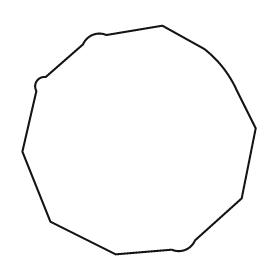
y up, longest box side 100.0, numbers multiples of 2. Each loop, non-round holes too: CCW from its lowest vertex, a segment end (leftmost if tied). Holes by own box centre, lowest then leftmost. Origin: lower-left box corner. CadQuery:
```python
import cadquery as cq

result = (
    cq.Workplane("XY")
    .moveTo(40.0, 0.0)
    .lineTo(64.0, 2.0)
    .threePointArc((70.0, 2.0), (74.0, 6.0))
    .lineTo(94.0, 24.0)
    .lineTo(100.0, 54.0)
    .lineTo(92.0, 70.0)
    .threePointArc((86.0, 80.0), (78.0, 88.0))
    .lineTo(60.0, 98.0)
    .lineTo(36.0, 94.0)
    .threePointArc((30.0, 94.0), (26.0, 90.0))
    .lineTo(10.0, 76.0)
    .threePointArc((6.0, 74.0), (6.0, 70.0))
    .lineTo(0.0, 44.0)
    .lineTo(12.0, 14.0)
    .close()
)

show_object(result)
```